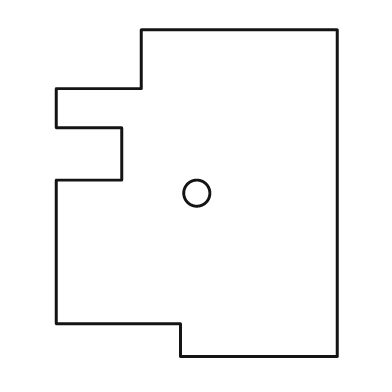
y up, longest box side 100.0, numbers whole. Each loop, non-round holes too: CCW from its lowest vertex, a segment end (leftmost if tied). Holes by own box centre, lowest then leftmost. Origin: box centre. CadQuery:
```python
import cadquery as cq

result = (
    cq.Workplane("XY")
    .moveTo(-5.0, -50.0)
    .lineTo(43.0, -50.0)
    .lineTo(43.0, 50.0)
    .lineTo(-17.0, 50.0)
    .lineTo(-17.0, 32.0)
    .lineTo(-43.0, 32.0)
    .lineTo(-43.0, 20.0)
    .lineTo(-23.0, 20.0)
    .lineTo(-23.0, 4.0)
    .lineTo(-43.0, 4.0)
    .lineTo(-43.0, -40.0)
    .lineTo(-5.0, -40.0)
    .close()
    .moveTo(0.0, 0.0)
    .circle(4.0)
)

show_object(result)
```